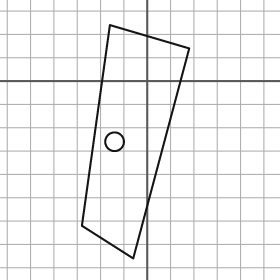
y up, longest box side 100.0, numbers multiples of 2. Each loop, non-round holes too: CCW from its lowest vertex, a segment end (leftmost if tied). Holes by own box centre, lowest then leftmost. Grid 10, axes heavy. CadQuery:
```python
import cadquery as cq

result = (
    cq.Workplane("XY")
    .moveTo(-6.0, -76.0)
    .lineTo(18.0, 14.0)
    .lineTo(-16.0, 24.0)
    .lineTo(-28.0, -62.0)
    .close()
    .moveTo(-14.0, -26.0)
    .circle(4.0)
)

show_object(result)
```